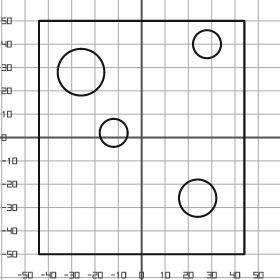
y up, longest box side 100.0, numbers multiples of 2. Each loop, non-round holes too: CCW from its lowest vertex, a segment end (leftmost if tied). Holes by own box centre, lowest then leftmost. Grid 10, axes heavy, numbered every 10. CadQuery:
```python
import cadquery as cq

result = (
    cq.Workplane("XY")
    .moveTo(-44.0, -50.0)
    .lineTo(44.0, -50.0)
    .lineTo(44.0, 50.0)
    .lineTo(-44.0, 50.0)
    .close()
    .moveTo(24.0, -26.0)
    .circle(8.0)
    .moveTo(-12.0, 2.0)
    .circle(6.0)
    .moveTo(-26.0, 28.0)
    .circle(10.0)
    .moveTo(28.0, 40.0)
    .circle(6.0)
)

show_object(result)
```